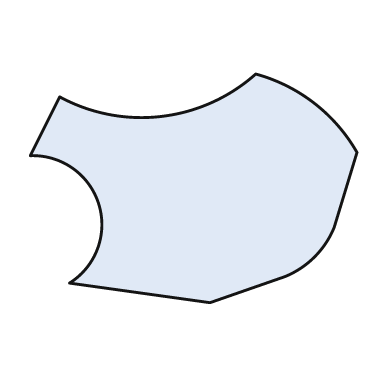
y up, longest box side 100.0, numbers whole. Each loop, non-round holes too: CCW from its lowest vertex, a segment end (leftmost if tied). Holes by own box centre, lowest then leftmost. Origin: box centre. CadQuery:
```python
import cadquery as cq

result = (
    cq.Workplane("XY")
    .moveTo(5.0, -35.0)
    .lineTo(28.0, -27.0)
    .threePointArc((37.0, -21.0), (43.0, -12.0))
    .lineTo(50.0, 11.0)
    .threePointArc((37.0, 26.0), (19.0, 35.0))
    .threePointArc((-10.0, 22.0), (-41.0, 28.0))
    .lineTo(-50.0, 10.0)
    .threePointArc((-29.0, -5.0), (-38.0, -29.0))
    .close()
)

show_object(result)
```